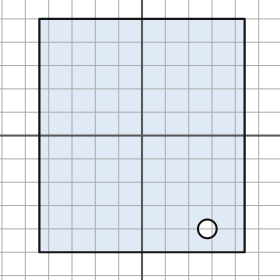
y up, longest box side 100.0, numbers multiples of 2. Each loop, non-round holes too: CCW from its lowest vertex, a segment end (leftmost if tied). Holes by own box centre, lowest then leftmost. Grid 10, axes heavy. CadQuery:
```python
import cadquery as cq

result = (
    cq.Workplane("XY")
    .moveTo(-44.0, -50.0)
    .lineTo(44.0, -50.0)
    .lineTo(44.0, 50.0)
    .lineTo(-44.0, 50.0)
    .close()
    .moveTo(28.0, -40.0)
    .circle(4.0)
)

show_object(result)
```